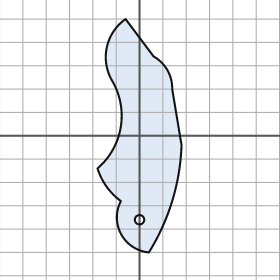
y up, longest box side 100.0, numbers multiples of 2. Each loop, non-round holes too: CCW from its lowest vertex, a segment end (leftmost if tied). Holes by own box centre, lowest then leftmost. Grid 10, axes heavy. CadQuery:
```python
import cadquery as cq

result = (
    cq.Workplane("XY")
    .moveTo(4.0, -50.0)
    .threePointArc((14.0, -28.0), (18.0, -4.0))
    .lineTo(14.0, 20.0)
    .threePointArc((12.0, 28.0), (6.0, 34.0))
    .lineTo(-6.0, 50.0)
    .threePointArc((-14.0, 38.0), (-12.0, 24.0))
    .threePointArc((-8.0, 4.0), (-18.0, -14.0))
    .threePointArc((-14.0, -22.0), (-8.0, -28.0))
    .threePointArc((-8.0, -42.0), (4.0, -50.0))
    .close()
    .moveTo(0.0, -36.0)
    .circle(2.0)
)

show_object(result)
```